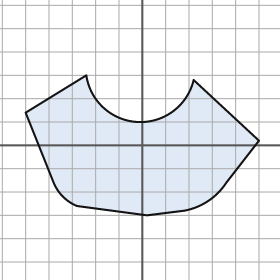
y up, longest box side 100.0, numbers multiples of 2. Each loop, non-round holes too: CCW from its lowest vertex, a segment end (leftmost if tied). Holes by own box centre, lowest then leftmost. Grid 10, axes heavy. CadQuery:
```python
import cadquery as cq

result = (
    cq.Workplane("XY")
    .moveTo(2.0, -30.0)
    .lineTo(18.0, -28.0)
    .threePointArc((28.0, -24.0), (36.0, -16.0))
    .lineTo(50.0, 2.0)
    .lineTo(22.0, 28.0)
    .threePointArc((-2.0, 10.0), (-24.0, 30.0))
    .lineTo(-50.0, 14.0)
    .lineTo(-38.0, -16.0)
    .threePointArc((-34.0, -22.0), (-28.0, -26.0))
    .close()
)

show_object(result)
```